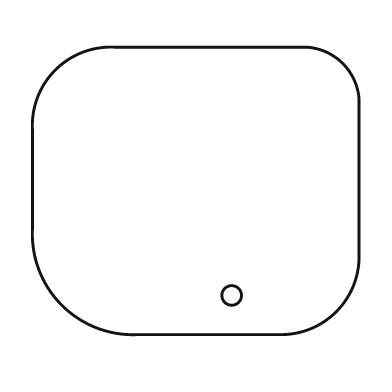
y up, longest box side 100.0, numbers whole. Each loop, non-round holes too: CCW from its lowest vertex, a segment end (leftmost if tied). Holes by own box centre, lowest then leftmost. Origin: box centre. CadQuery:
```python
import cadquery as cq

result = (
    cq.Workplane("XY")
    .moveTo(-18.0, -44.0)
    .lineTo(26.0, -44.0)
    .threePointArc((43.0, -37.0), (50.0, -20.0))
    .lineTo(50.0, 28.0)
    .threePointArc((45.0, 39.0), (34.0, 44.0))
    .lineTo(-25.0, 44.0)
    .threePointArc((-43.0, 37.0), (-50.0, 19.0))
    .lineTo(-50.0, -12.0)
    .threePointArc((-41.0, -35.0), (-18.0, -44.0))
    .close()
    .moveTo(11.0, -32.0)
    .circle(3.0)
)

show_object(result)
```